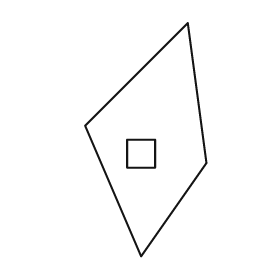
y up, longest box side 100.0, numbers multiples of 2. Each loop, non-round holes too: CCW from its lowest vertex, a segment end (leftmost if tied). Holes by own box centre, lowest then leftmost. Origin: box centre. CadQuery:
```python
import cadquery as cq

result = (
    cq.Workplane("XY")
    .moveTo(-2.0, -50.0)
    .lineTo(26.0, -10.0)
    .lineTo(18.0, 50.0)
    .lineTo(-26.0, 6.0)
    .close()
    .moveTo(-8.0, -12.0)
    .lineTo(4.0, -12.0)
    .lineTo(4.0, 0.0)
    .lineTo(-8.0, 0.0)
    .close()
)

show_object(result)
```